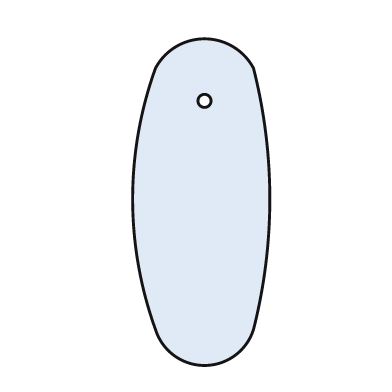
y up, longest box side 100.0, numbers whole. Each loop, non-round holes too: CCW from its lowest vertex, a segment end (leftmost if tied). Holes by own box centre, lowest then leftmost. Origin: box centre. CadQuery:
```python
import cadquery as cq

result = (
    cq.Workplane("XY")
    .moveTo(-14.0, -39.0)
    .threePointArc((1.0, -50.0), (16.0, -39.0))
    .threePointArc((21.0, 1.0), (16.0, 41.0))
    .threePointArc((1.0, 50.0), (-14.0, 41.0))
    .threePointArc((-21.0, 1.0), (-14.0, -39.0))
    .close()
    .moveTo(1.0, 31.0)
    .circle(2.0)
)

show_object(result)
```